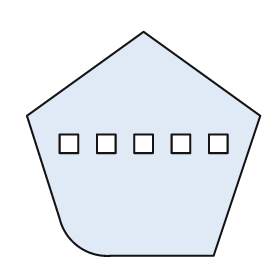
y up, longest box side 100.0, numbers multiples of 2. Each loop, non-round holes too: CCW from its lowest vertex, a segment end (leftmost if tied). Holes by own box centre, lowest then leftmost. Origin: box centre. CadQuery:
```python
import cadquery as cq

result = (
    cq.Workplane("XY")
    .moveTo(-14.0, -48.0)
    .lineTo(30.0, -48.0)
    .lineTo(50.0, 12.0)
    .lineTo(0.0, 48.0)
    .lineTo(-50.0, 12.0)
    .lineTo(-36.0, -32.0)
    .threePointArc((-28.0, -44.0), (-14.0, -48.0))
    .close()
    .moveTo(-36.0, -4.0)
    .lineTo(-28.0, -4.0)
    .lineTo(-28.0, 4.0)
    .lineTo(-36.0, 4.0)
    .close()
    .moveTo(-20.0, -4.0)
    .lineTo(-12.0, -4.0)
    .lineTo(-12.0, 4.0)
    .lineTo(-20.0, 4.0)
    .close()
    .moveTo(-4.0, -4.0)
    .lineTo(4.0, -4.0)
    .lineTo(4.0, 4.0)
    .lineTo(-4.0, 4.0)
    .close()
    .moveTo(12.0, -4.0)
    .lineTo(20.0, -4.0)
    .lineTo(20.0, 4.0)
    .lineTo(12.0, 4.0)
    .close()
    .moveTo(28.0, -4.0)
    .lineTo(36.0, -4.0)
    .lineTo(36.0, 4.0)
    .lineTo(28.0, 4.0)
    .close()
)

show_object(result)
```